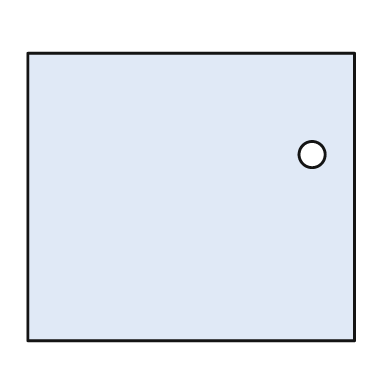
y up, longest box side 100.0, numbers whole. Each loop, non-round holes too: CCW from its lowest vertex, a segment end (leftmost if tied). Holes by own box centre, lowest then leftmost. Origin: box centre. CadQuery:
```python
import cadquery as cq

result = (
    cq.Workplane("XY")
    .moveTo(-50.0, -44.0)
    .lineTo(50.0, -44.0)
    .lineTo(50.0, 44.0)
    .lineTo(-50.0, 44.0)
    .close()
    .moveTo(37.0, 13.0)
    .circle(4.0)
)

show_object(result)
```